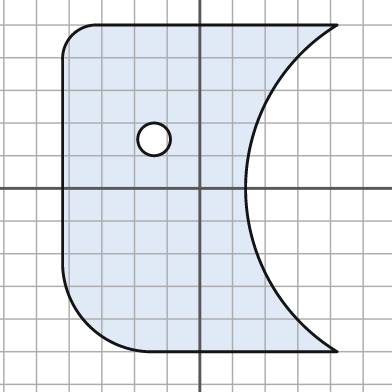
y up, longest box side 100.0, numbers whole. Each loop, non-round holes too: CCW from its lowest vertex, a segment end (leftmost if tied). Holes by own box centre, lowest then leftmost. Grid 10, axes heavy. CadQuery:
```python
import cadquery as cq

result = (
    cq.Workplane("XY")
    .moveTo(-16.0, -50.0)
    .lineTo(42.0, -50.0)
    .threePointArc((14.0, 0.0), (42.0, 50.0))
    .lineTo(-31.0, 50.0)
    .threePointArc((-39.0, 47.0), (-42.0, 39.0))
    .lineTo(-42.0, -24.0)
    .threePointArc((-34.0, -42.0), (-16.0, -50.0))
    .close()
    .moveTo(-14.0, 15.0)
    .circle(5.0)
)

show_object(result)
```